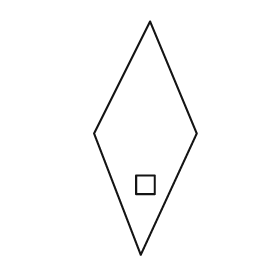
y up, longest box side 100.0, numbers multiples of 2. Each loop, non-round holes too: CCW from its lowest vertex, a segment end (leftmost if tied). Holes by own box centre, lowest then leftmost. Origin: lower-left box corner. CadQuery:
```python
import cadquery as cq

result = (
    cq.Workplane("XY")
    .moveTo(20.0, 0.0)
    .lineTo(44.0, 52.0)
    .lineTo(24.0, 100.0)
    .lineTo(0.0, 52.0)
    .close()
    .moveTo(18.0, 26.0)
    .lineTo(26.0, 26.0)
    .lineTo(26.0, 34.0)
    .lineTo(18.0, 34.0)
    .close()
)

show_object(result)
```